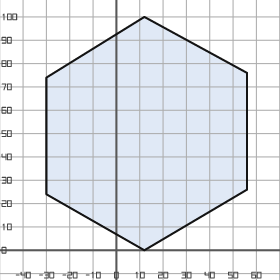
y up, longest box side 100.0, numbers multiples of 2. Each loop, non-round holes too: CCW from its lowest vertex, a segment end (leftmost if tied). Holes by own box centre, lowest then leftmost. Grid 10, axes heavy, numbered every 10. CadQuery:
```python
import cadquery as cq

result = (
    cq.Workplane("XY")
    .moveTo(12.0, 0.0)
    .lineTo(56.0, 26.0)
    .lineTo(56.0, 76.0)
    .lineTo(12.0, 100.0)
    .lineTo(-30.0, 74.0)
    .lineTo(-30.0, 24.0)
    .close()
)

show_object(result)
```